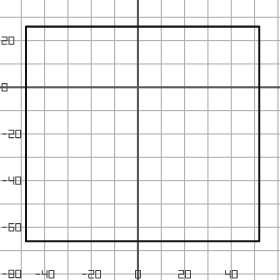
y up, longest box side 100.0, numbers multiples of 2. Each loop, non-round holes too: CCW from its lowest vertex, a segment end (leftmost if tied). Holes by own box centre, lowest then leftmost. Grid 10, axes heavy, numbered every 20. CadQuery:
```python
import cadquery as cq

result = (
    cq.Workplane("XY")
    .moveTo(-48.0, -66.0)
    .lineTo(52.0, -66.0)
    .lineTo(52.0, 26.0)
    .lineTo(-48.0, 26.0)
    .close()
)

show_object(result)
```